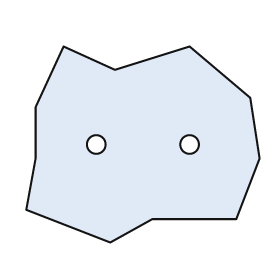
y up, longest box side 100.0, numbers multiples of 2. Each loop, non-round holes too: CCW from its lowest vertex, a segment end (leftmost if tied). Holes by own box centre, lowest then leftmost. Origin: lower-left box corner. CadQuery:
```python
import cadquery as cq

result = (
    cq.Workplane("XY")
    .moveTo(36.0, 0.0)
    .lineTo(54.0, 10.0)
    .lineTo(90.0, 10.0)
    .lineTo(100.0, 36.0)
    .lineTo(96.0, 62.0)
    .lineTo(70.0, 84.0)
    .lineTo(38.0, 74.0)
    .lineTo(16.0, 84.0)
    .lineTo(4.0, 58.0)
    .lineTo(4.0, 36.0)
    .lineTo(0.0, 14.0)
    .close()
    .moveTo(30.0, 42.0)
    .circle(4.0)
    .moveTo(70.0, 42.0)
    .circle(4.0)
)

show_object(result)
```